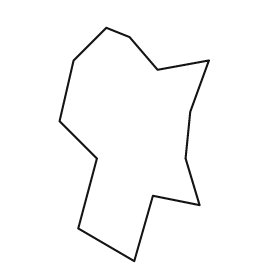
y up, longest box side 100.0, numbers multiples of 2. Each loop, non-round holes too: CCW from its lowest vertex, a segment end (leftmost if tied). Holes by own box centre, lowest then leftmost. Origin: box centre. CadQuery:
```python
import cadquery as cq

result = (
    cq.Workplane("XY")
    .moveTo(0.0, -50.0)
    .lineTo(8.0, -22.0)
    .lineTo(28.0, -26.0)
    .lineTo(22.0, -6.0)
    .lineTo(24.0, 14.0)
    .lineTo(32.0, 36.0)
    .lineTo(10.0, 32.0)
    .lineTo(-2.0, 46.0)
    .lineTo(-12.0, 50.0)
    .lineTo(-26.0, 36.0)
    .lineTo(-32.0, 10.0)
    .lineTo(-16.0, -6.0)
    .lineTo(-24.0, -36.0)
    .close()
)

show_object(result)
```